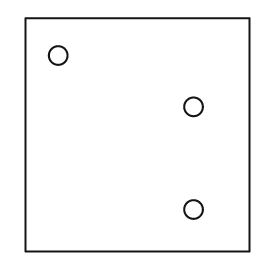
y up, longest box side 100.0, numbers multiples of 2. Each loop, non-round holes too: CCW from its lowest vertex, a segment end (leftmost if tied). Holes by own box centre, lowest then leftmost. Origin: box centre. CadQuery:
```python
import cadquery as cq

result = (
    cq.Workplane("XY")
    .moveTo(-48.0, -50.0)
    .lineTo(48.0, -50.0)
    .lineTo(48.0, 50.0)
    .lineTo(-48.0, 50.0)
    .close()
    .moveTo(24.0, -32.0)
    .circle(4.0)
    .moveTo(24.0, 12.0)
    .circle(4.0)
    .moveTo(-34.0, 34.0)
    .circle(4.0)
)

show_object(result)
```